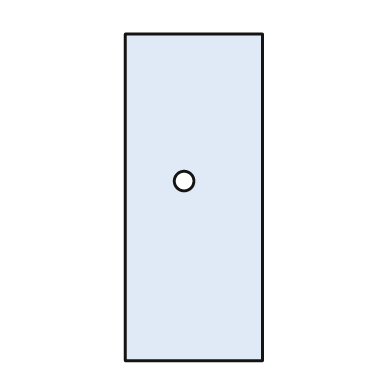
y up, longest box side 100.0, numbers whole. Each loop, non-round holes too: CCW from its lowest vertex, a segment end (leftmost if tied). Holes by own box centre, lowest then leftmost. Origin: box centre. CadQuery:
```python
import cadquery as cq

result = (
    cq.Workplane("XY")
    .moveTo(-21.0, -50.0)
    .lineTo(21.0, -50.0)
    .lineTo(21.0, 50.0)
    .lineTo(-21.0, 50.0)
    .close()
    .moveTo(-3.0, 5.0)
    .circle(3.0)
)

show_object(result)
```